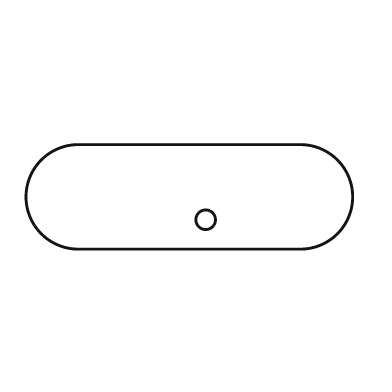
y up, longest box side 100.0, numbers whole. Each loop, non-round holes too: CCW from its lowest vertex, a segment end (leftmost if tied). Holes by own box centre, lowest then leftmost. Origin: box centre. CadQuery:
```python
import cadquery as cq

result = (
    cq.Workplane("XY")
    .moveTo(-34.0, -16.0)
    .lineTo(34.0, -16.0)
    .threePointArc((50.0, 0.0), (34.0, 16.0))
    .lineTo(-34.0, 16.0)
    .threePointArc((-50.0, 0.0), (-34.0, -16.0))
    .close()
    .moveTo(5.0, -7.0)
    .circle(3.0)
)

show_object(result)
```